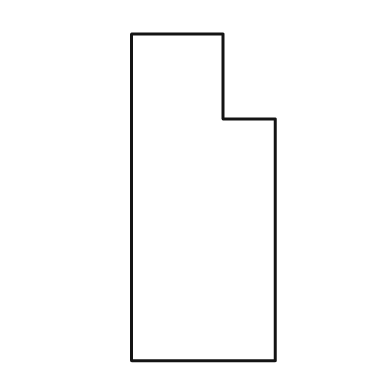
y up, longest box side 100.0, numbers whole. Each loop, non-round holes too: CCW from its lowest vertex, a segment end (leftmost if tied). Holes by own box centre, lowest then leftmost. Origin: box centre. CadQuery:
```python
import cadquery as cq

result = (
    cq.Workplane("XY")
    .moveTo(-22.0, -50.0)
    .lineTo(22.0, -50.0)
    .lineTo(22.0, 24.0)
    .lineTo(6.0, 24.0)
    .lineTo(6.0, 50.0)
    .lineTo(-22.0, 50.0)
    .close()
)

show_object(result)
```